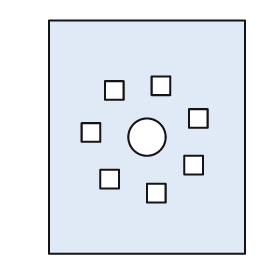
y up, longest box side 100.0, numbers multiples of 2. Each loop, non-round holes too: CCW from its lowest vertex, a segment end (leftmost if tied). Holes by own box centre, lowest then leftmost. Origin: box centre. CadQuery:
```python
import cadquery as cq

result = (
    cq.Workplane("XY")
    .moveTo(-42.0, -50.0)
    .lineTo(42.0, -50.0)
    .lineTo(42.0, 50.0)
    .lineTo(-42.0, 50.0)
    .close()
    .moveTo(0.0, -28.0)
    .lineTo(8.0, -28.0)
    .lineTo(8.0, -20.0)
    .lineTo(0.0, -20.0)
    .close()
    .moveTo(-20.0, -22.0)
    .lineTo(-12.0, -22.0)
    .lineTo(-12.0, -14.0)
    .lineTo(-20.0, -14.0)
    .close()
    .moveTo(16.0, -16.0)
    .lineTo(24.0, -16.0)
    .lineTo(24.0, -8.0)
    .lineTo(16.0, -8.0)
    .close()
    .moveTo(0.0, 0.0)
    .circle(8.0)
    .moveTo(-28.0, -2.0)
    .lineTo(-20.0, -2.0)
    .lineTo(-20.0, 6.0)
    .lineTo(-28.0, 6.0)
    .close()
    .moveTo(18.0, 4.0)
    .lineTo(26.0, 4.0)
    .lineTo(26.0, 12.0)
    .lineTo(18.0, 12.0)
    .close()
    .moveTo(-18.0, 16.0)
    .lineTo(-10.0, 16.0)
    .lineTo(-10.0, 24.0)
    .lineTo(-18.0, 24.0)
    .close()
    .moveTo(2.0, 18.0)
    .lineTo(10.0, 18.0)
    .lineTo(10.0, 26.0)
    .lineTo(2.0, 26.0)
    .close()
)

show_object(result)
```